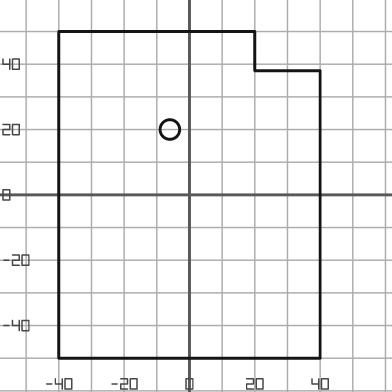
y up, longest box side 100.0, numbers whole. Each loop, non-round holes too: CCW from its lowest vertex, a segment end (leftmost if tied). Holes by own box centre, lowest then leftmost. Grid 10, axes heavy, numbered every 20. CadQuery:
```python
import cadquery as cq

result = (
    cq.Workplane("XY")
    .moveTo(-40.0, -50.0)
    .lineTo(40.0, -50.0)
    .lineTo(40.0, 38.0)
    .lineTo(20.0, 38.0)
    .lineTo(20.0, 50.0)
    .lineTo(-40.0, 50.0)
    .close()
    .moveTo(-6.0, 20.0)
    .circle(3.0)
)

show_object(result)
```